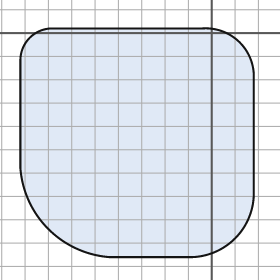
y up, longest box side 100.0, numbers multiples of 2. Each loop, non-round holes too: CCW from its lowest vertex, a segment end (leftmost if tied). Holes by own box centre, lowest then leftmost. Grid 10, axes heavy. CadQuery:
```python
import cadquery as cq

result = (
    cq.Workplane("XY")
    .moveTo(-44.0, -96.0)
    .lineTo(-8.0, -96.0)
    .threePointArc((10.0, -88.0), (18.0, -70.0))
    .lineTo(18.0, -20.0)
    .threePointArc((12.0, -4.0), (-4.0, 2.0))
    .lineTo(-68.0, 2.0)
    .threePointArc((-78.0, -2.0), (-82.0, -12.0))
    .lineTo(-82.0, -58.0)
    .threePointArc((-70.0, -84.0), (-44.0, -96.0))
    .close()
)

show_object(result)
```